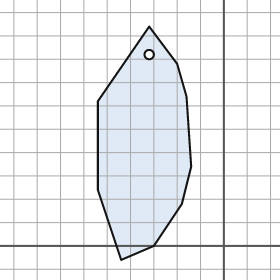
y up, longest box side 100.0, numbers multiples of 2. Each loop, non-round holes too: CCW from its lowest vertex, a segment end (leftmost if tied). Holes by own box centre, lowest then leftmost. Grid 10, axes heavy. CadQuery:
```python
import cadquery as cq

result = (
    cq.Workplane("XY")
    .moveTo(-44.0, -6.0)
    .lineTo(-30.0, 0.0)
    .lineTo(-18.0, 18.0)
    .lineTo(-14.0, 34.0)
    .lineTo(-16.0, 64.0)
    .lineTo(-20.0, 78.0)
    .lineTo(-32.0, 94.0)
    .lineTo(-54.0, 62.0)
    .lineTo(-54.0, 24.0)
    .close()
    .moveTo(-32.0, 82.0)
    .circle(2.0)
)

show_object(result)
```